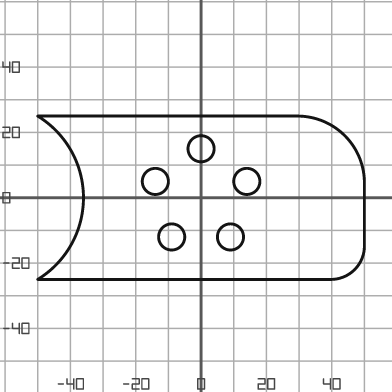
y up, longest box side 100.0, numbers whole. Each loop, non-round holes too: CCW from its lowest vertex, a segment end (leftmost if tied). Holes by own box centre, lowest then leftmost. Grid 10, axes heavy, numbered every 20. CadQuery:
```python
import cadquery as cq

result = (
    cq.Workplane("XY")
    .moveTo(-50.0, -25.0)
    .lineTo(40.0, -25.0)
    .threePointArc((47.0, -22.0), (50.0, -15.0))
    .lineTo(50.0, 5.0)
    .threePointArc((44.0, 19.0), (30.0, 25.0))
    .lineTo(-50.0, 25.0)
    .threePointArc((-36.0, 0.0), (-50.0, -25.0))
    .close()
    .moveTo(-9.0, -12.0)
    .circle(4.0)
    .moveTo(9.0, -12.0)
    .circle(4.0)
    .moveTo(-14.0, 5.0)
    .circle(4.0)
    .moveTo(14.0, 5.0)
    .circle(4.0)
    .moveTo(0.0, 15.0)
    .circle(4.0)
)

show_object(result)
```